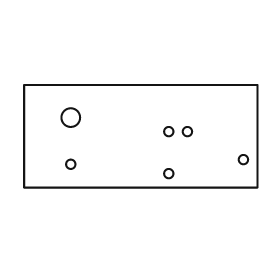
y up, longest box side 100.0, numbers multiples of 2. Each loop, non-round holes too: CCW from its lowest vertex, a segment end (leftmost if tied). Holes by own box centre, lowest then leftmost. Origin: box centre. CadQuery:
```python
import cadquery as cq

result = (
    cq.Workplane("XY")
    .moveTo(-50.0, -22.0)
    .lineTo(50.0, -22.0)
    .lineTo(50.0, 22.0)
    .lineTo(-50.0, 22.0)
    .close()
    .moveTo(12.0, -16.0)
    .circle(2.0)
    .moveTo(-30.0, -12.0)
    .circle(2.0)
    .moveTo(44.0, -10.0)
    .circle(2.0)
    .moveTo(12.0, 2.0)
    .circle(2.0)
    .moveTo(20.0, 2.0)
    .circle(2.0)
    .moveTo(-30.0, 8.0)
    .circle(4.0)
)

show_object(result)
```